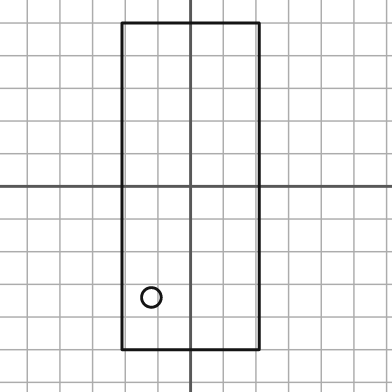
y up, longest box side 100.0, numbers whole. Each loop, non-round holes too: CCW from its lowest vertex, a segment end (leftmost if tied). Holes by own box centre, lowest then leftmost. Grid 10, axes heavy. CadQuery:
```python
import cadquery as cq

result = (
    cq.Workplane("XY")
    .moveTo(-21.0, -50.0)
    .lineTo(21.0, -50.0)
    .lineTo(21.0, 50.0)
    .lineTo(-21.0, 50.0)
    .close()
    .moveTo(-12.0, -34.0)
    .circle(3.0)
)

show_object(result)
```